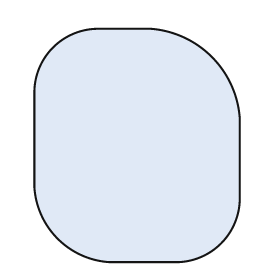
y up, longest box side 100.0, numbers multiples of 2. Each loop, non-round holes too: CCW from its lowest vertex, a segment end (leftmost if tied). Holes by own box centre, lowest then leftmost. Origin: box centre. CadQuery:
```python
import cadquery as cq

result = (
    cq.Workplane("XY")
    .moveTo(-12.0, -50.0)
    .lineTo(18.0, -50.0)
    .threePointArc((36.0, -42.0), (44.0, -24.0))
    .lineTo(44.0, 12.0)
    .threePointArc((32.0, 38.0), (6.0, 50.0))
    .lineTo(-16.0, 50.0)
    .threePointArc((-36.0, 42.0), (-44.0, 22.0))
    .lineTo(-44.0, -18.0)
    .threePointArc((-34.0, -40.0), (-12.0, -50.0))
    .close()
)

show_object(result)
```